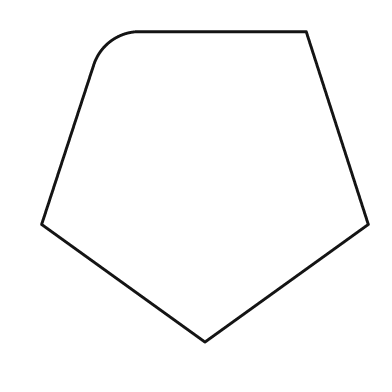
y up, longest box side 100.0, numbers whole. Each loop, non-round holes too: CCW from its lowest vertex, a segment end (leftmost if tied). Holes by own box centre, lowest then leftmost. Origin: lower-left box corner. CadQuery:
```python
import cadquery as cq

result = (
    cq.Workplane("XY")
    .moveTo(50.0, 0.0)
    .lineTo(100.0, 36.0)
    .lineTo(81.0, 95.0)
    .lineTo(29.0, 95.0)
    .threePointArc((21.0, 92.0), (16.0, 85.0))
    .lineTo(0.0, 36.0)
    .close()
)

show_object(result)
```